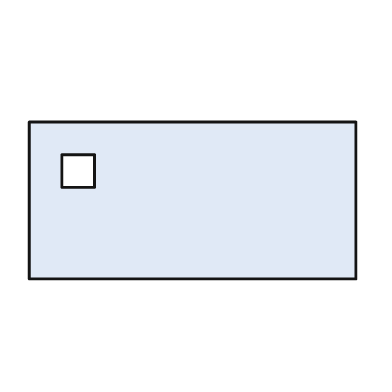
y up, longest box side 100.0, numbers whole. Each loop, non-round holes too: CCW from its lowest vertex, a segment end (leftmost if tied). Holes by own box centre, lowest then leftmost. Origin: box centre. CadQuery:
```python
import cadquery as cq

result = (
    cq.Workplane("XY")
    .moveTo(-50.0, -24.0)
    .lineTo(50.0, -24.0)
    .lineTo(50.0, 24.0)
    .lineTo(-50.0, 24.0)
    .close()
    .moveTo(-40.0, 4.0)
    .lineTo(-30.0, 4.0)
    .lineTo(-30.0, 14.0)
    .lineTo(-40.0, 14.0)
    .close()
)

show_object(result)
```